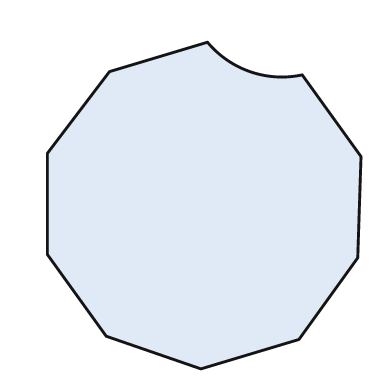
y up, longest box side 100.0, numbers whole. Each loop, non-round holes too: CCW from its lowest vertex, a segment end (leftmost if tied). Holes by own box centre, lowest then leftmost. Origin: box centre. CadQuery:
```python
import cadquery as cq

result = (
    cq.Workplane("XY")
    .moveTo(-1.0, -50.0)
    .lineTo(29.0, -41.0)
    .lineTo(47.0, -16.0)
    .lineTo(48.0, 15.0)
    .lineTo(30.0, 40.0)
    .threePointArc((14.0, 41.0), (1.0, 50.0))
    .lineTo(-29.0, 41.0)
    .lineTo(-48.0, 16.0)
    .lineTo(-48.0, -15.0)
    .lineTo(-30.0, -40.0)
    .close()
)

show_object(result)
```